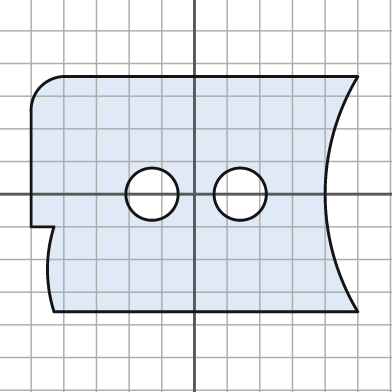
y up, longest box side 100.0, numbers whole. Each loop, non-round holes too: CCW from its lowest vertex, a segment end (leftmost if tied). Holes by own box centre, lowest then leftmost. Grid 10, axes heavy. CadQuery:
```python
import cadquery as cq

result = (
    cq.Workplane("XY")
    .moveTo(-43.0, -36.0)
    .lineTo(50.0, -36.0)
    .threePointArc((40.0, 0.0), (50.0, 36.0))
    .lineTo(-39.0, 36.0)
    .threePointArc((-47.0, 33.0), (-50.0, 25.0))
    .lineTo(-50.0, -10.0)
    .lineTo(-43.0, -10.0)
    .threePointArc((-45.0, -23.0), (-43.0, -36.0))
    .close()
    .moveTo(-13.0, 0.0)
    .circle(8.0)
    .moveTo(14.0, 0.0)
    .circle(8.0)
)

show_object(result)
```